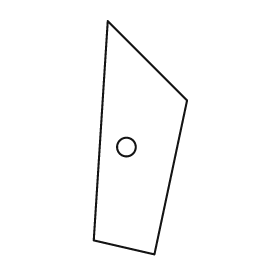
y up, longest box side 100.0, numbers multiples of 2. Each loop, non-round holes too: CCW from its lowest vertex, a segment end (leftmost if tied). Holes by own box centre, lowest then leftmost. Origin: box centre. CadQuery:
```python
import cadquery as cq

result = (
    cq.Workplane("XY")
    .moveTo(6.0, -50.0)
    .lineTo(20.0, 16.0)
    .lineTo(-14.0, 50.0)
    .lineTo(-20.0, -44.0)
    .close()
    .moveTo(-6.0, -4.0)
    .circle(4.0)
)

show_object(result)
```